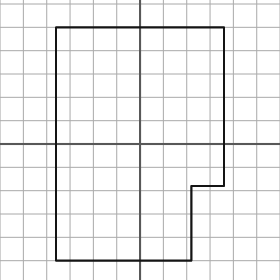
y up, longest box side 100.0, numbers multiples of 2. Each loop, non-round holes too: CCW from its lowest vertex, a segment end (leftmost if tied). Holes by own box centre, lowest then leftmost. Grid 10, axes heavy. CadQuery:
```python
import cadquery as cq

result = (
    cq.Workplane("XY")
    .moveTo(-36.0, -50.0)
    .lineTo(22.0, -50.0)
    .lineTo(22.0, -18.0)
    .lineTo(36.0, -18.0)
    .lineTo(36.0, 50.0)
    .lineTo(-36.0, 50.0)
    .close()
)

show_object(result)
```